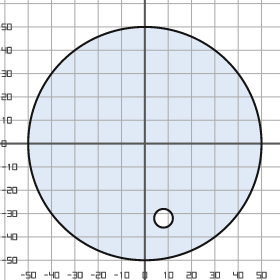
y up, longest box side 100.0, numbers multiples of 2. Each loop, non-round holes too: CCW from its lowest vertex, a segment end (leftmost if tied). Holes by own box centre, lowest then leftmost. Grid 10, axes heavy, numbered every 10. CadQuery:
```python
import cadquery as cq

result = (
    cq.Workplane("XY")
    .moveTo(0.0, 0.0)
    .circle(50.0)
    .moveTo(8.0, -32.0)
    .circle(4.0)
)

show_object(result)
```